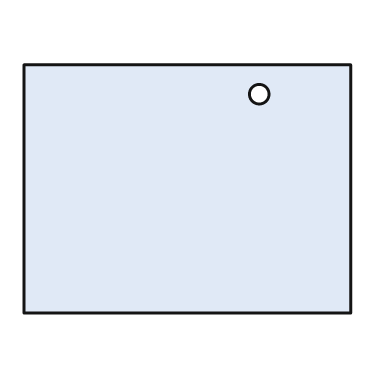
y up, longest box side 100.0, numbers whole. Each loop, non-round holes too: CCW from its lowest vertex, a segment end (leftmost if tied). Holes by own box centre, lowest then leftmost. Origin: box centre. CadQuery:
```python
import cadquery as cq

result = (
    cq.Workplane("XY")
    .moveTo(-50.0, -38.0)
    .lineTo(50.0, -38.0)
    .lineTo(50.0, 38.0)
    .lineTo(-50.0, 38.0)
    .close()
    .moveTo(22.0, 29.0)
    .circle(3.0)
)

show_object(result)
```